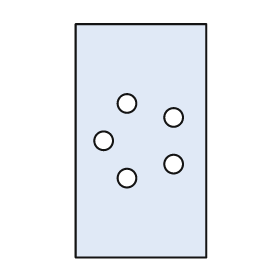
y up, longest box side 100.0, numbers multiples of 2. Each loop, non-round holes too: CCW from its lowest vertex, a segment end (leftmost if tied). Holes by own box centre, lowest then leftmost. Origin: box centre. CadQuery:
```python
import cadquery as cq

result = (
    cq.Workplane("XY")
    .moveTo(-28.0, -50.0)
    .lineTo(28.0, -50.0)
    .lineTo(28.0, 50.0)
    .lineTo(-28.0, 50.0)
    .close()
    .moveTo(-6.0, -16.0)
    .circle(4.0)
    .moveTo(14.0, -10.0)
    .circle(4.0)
    .moveTo(-16.0, 0.0)
    .circle(4.0)
    .moveTo(14.0, 10.0)
    .circle(4.0)
    .moveTo(-6.0, 16.0)
    .circle(4.0)
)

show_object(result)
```